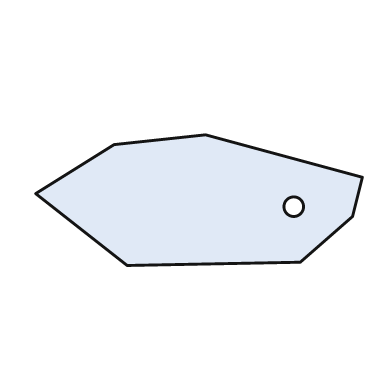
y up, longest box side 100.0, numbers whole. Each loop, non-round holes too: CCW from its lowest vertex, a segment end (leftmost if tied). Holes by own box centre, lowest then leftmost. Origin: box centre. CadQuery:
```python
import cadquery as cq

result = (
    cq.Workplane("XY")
    .moveTo(-22.0, -20.0)
    .lineTo(31.0, -19.0)
    .lineTo(47.0, -5.0)
    .lineTo(50.0, 7.0)
    .lineTo(2.0, 20.0)
    .lineTo(-26.0, 17.0)
    .lineTo(-50.0, 2.0)
    .close()
    .moveTo(29.0, -2.0)
    .circle(3.0)
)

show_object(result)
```